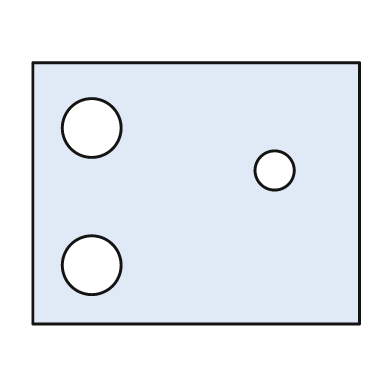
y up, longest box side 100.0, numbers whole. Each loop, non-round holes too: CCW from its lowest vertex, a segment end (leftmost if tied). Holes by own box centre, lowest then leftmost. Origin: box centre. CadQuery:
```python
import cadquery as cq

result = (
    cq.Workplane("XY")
    .moveTo(-50.0, -40.0)
    .lineTo(50.0, -40.0)
    .lineTo(50.0, 40.0)
    .lineTo(-50.0, 40.0)
    .close()
    .moveTo(-32.0, -22.0)
    .circle(9.0)
    .moveTo(24.0, 7.0)
    .circle(6.0)
    .moveTo(-32.0, 20.0)
    .circle(9.0)
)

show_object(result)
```